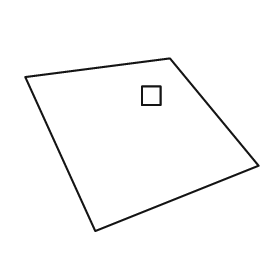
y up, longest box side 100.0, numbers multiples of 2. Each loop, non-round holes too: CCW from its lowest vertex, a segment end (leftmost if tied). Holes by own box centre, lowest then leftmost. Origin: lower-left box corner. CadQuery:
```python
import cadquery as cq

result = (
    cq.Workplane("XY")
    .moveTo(30.0, 0.0)
    .lineTo(100.0, 28.0)
    .lineTo(62.0, 74.0)
    .lineTo(0.0, 66.0)
    .close()
    .moveTo(50.0, 54.0)
    .lineTo(58.0, 54.0)
    .lineTo(58.0, 62.0)
    .lineTo(50.0, 62.0)
    .close()
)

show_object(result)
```